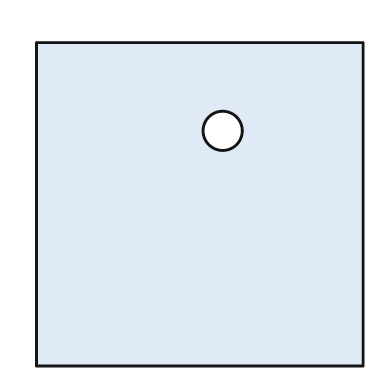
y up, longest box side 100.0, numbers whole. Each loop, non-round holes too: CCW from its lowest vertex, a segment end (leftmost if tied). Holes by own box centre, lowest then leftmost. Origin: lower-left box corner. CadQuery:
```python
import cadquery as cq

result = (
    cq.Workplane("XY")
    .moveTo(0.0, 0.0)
    .lineTo(100.0, 0.0)
    .lineTo(100.0, 99.0)
    .lineTo(0.0, 99.0)
    .close()
    .moveTo(57.0, 72.0)
    .circle(6.0)
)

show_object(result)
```